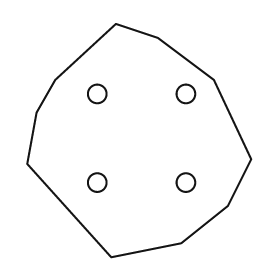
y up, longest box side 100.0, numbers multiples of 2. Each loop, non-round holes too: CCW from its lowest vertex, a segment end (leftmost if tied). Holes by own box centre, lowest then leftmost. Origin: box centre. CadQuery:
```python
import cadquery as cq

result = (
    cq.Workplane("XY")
    .moveTo(-12.0, -50.0)
    .lineTo(18.0, -44.0)
    .lineTo(38.0, -28.0)
    .lineTo(48.0, -8.0)
    .lineTo(32.0, 26.0)
    .lineTo(8.0, 44.0)
    .lineTo(-10.0, 50.0)
    .lineTo(-36.0, 26.0)
    .lineTo(-44.0, 12.0)
    .lineTo(-48.0, -10.0)
    .close()
    .moveTo(-18.0, -18.0)
    .circle(4.0)
    .moveTo(20.0, -18.0)
    .circle(4.0)
    .moveTo(-18.0, 20.0)
    .circle(4.0)
    .moveTo(20.0, 20.0)
    .circle(4.0)
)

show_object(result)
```